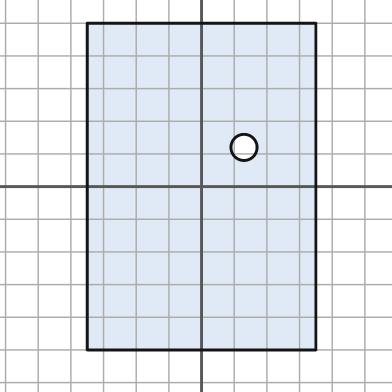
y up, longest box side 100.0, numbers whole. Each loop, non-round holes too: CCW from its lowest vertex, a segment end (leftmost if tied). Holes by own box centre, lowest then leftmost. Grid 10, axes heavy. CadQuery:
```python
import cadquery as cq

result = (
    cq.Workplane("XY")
    .moveTo(-35.0, -50.0)
    .lineTo(35.0, -50.0)
    .lineTo(35.0, 50.0)
    .lineTo(-35.0, 50.0)
    .close()
    .moveTo(13.0, 12.0)
    .circle(4.0)
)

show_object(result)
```